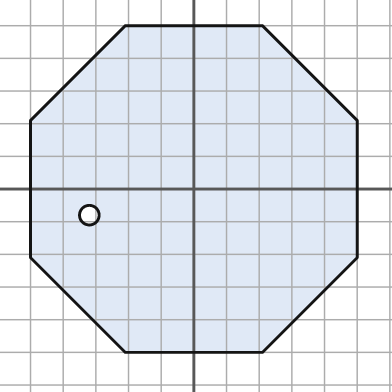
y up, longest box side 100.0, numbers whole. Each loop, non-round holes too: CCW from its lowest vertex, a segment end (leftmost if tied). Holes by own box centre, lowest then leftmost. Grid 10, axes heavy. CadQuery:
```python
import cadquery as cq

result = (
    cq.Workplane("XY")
    .moveTo(-21.0, -50.0)
    .lineTo(21.0, -50.0)
    .lineTo(50.0, -21.0)
    .lineTo(50.0, 21.0)
    .lineTo(21.0, 50.0)
    .lineTo(-21.0, 50.0)
    .lineTo(-50.0, 21.0)
    .lineTo(-50.0, -21.0)
    .close()
    .moveTo(-32.0, -8.0)
    .circle(3.0)
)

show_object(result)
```